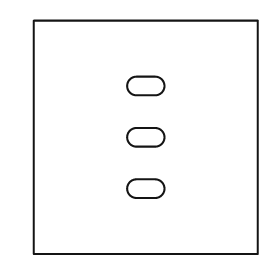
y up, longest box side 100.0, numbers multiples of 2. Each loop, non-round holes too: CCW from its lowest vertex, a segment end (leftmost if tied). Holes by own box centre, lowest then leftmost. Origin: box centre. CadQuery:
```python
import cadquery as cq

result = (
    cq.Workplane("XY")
    .moveTo(-48.0, -50.0)
    .lineTo(48.0, -50.0)
    .lineTo(48.0, 50.0)
    .lineTo(-48.0, 50.0)
    .close()
    .moveTo(-4.0, -26.0)
    .lineTo(4.0, -26.0)
    .threePointArc((8.0, -22.0), (4.0, -18.0))
    .lineTo(-4.0, -18.0)
    .threePointArc((-8.0, -22.0), (-4.0, -26.0))
    .close()
    .moveTo(-4.0, -4.0)
    .lineTo(4.0, -4.0)
    .threePointArc((8.0, 0.0), (4.0, 4.0))
    .lineTo(-4.0, 4.0)
    .threePointArc((-8.0, 0.0), (-4.0, -4.0))
    .close()
    .moveTo(-4.0, 18.0)
    .lineTo(4.0, 18.0)
    .threePointArc((8.0, 22.0), (4.0, 26.0))
    .lineTo(-4.0, 26.0)
    .threePointArc((-8.0, 22.0), (-4.0, 18.0))
    .close()
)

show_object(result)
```